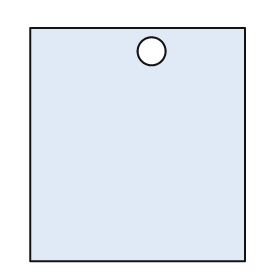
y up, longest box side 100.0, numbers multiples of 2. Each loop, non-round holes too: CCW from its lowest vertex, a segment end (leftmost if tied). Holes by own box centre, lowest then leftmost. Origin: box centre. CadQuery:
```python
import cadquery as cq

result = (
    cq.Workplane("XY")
    .moveTo(-46.0, -50.0)
    .lineTo(46.0, -50.0)
    .lineTo(46.0, 50.0)
    .lineTo(-46.0, 50.0)
    .close()
    .moveTo(6.0, 40.0)
    .circle(6.0)
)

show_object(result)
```